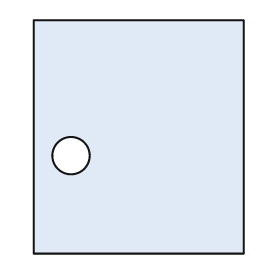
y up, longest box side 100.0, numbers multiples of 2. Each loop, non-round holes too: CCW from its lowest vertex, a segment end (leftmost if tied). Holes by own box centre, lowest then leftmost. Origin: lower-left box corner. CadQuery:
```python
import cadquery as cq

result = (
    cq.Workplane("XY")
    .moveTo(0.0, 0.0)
    .lineTo(90.0, 0.0)
    .lineTo(90.0, 100.0)
    .lineTo(0.0, 100.0)
    .close()
    .moveTo(16.0, 42.0)
    .circle(8.0)
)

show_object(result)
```